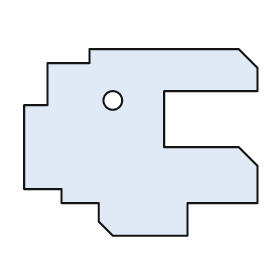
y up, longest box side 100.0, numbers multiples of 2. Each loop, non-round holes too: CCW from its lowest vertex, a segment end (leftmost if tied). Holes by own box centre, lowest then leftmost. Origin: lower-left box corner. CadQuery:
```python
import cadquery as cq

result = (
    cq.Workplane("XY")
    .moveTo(38.0, 0.0)
    .lineTo(70.0, 0.0)
    .lineTo(70.0, 14.0)
    .lineTo(100.0, 14.0)
    .lineTo(100.0, 30.0)
    .lineTo(92.0, 38.0)
    .lineTo(60.0, 38.0)
    .lineTo(60.0, 62.0)
    .lineTo(100.0, 62.0)
    .lineTo(100.0, 72.0)
    .lineTo(92.0, 80.0)
    .lineTo(28.0, 80.0)
    .lineTo(28.0, 74.0)
    .lineTo(10.0, 74.0)
    .lineTo(10.0, 56.0)
    .lineTo(0.0, 56.0)
    .lineTo(0.0, 20.0)
    .lineTo(16.0, 20.0)
    .lineTo(16.0, 14.0)
    .lineTo(32.0, 14.0)
    .lineTo(32.0, 6.0)
    .close()
    .moveTo(38.0, 58.0)
    .circle(4.0)
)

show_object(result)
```